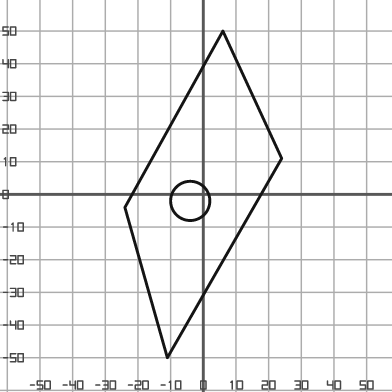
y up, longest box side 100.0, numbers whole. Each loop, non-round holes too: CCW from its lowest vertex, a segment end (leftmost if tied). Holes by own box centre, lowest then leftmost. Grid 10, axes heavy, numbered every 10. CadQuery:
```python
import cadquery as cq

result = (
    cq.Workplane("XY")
    .moveTo(-11.0, -50.0)
    .lineTo(24.0, 11.0)
    .lineTo(6.0, 50.0)
    .lineTo(-24.0, -4.0)
    .close()
    .moveTo(-4.0, -2.0)
    .circle(6.0)
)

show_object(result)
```